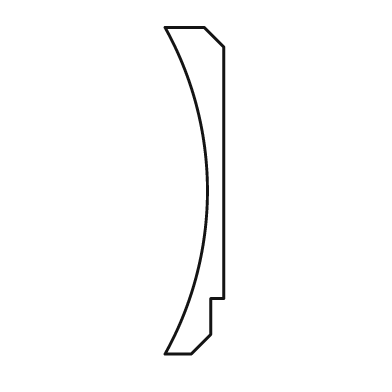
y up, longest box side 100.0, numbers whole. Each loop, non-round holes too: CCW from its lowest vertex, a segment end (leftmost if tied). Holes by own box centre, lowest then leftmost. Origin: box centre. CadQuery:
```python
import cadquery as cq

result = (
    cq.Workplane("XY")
    .moveTo(-9.0, -50.0)
    .lineTo(-1.0, -50.0)
    .lineTo(5.0, -44.0)
    .lineTo(5.0, -33.0)
    .lineTo(9.0, -33.0)
    .lineTo(9.0, 44.0)
    .lineTo(3.0, 50.0)
    .lineTo(-9.0, 50.0)
    .threePointArc((4.0, 0.0), (-9.0, -50.0))
    .close()
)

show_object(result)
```